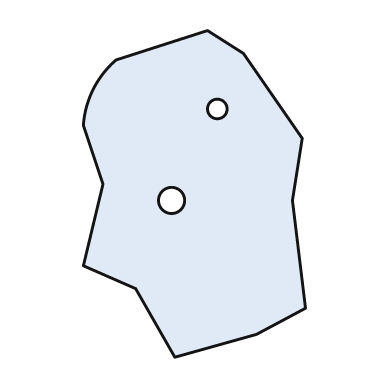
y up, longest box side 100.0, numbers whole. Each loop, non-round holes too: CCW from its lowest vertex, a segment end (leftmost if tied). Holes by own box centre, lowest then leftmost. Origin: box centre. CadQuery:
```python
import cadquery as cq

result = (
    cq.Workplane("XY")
    .moveTo(-6.0, -50.0)
    .lineTo(19.0, -43.0)
    .lineTo(34.0, -35.0)
    .lineTo(30.0, -2.0)
    .lineTo(33.0, 17.0)
    .lineTo(15.0, 43.0)
    .lineTo(4.0, 50.0)
    .lineTo(-24.0, 41.0)
    .threePointArc((-31.0, 32.0), (-34.0, 21.0))
    .lineTo(-28.0, 3.0)
    .lineTo(-34.0, -22.0)
    .lineTo(-18.0, -29.0)
    .close()
    .moveTo(-7.0, -2.0)
    .circle(4.0)
    .moveTo(7.0, 26.0)
    .circle(3.0)
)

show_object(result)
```